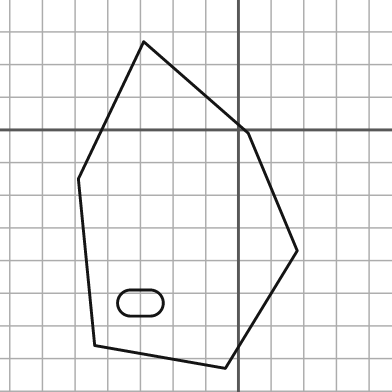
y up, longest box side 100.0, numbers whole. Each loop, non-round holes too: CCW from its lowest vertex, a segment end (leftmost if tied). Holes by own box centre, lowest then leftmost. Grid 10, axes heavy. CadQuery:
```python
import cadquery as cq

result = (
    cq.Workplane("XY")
    .moveTo(-4.0, -73.0)
    .lineTo(18.0, -37.0)
    .lineTo(3.0, -1.0)
    .lineTo(-29.0, 27.0)
    .lineTo(-49.0, -15.0)
    .lineTo(-44.0, -66.0)
    .close()
    .moveTo(-33.0, -57.0)
    .lineTo(-27.0, -57.0)
    .threePointArc((-23.0, -53.0), (-27.0, -49.0))
    .lineTo(-33.0, -49.0)
    .threePointArc((-37.0, -53.0), (-33.0, -57.0))
    .close()
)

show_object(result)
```